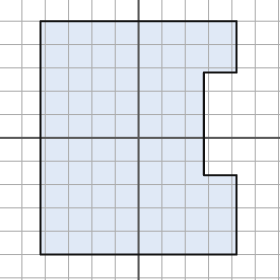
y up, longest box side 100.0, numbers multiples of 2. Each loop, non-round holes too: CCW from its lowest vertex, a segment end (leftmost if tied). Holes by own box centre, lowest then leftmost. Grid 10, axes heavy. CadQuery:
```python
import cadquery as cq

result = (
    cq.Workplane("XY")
    .moveTo(-42.0, -50.0)
    .lineTo(42.0, -50.0)
    .lineTo(42.0, -16.0)
    .lineTo(28.0, -16.0)
    .lineTo(28.0, 28.0)
    .lineTo(42.0, 28.0)
    .lineTo(42.0, 50.0)
    .lineTo(-42.0, 50.0)
    .close()
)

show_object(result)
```